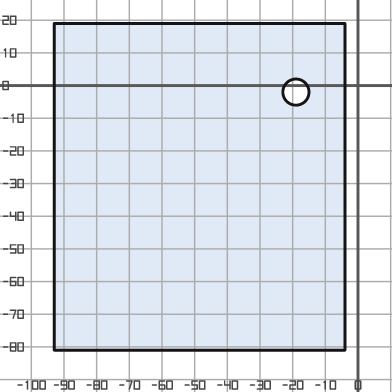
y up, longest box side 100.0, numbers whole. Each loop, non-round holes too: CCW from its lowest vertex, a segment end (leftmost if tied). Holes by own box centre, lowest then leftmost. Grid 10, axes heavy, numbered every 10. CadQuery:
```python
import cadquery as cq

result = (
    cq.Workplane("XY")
    .moveTo(-93.0, -81.0)
    .lineTo(-4.0, -81.0)
    .lineTo(-4.0, 19.0)
    .lineTo(-93.0, 19.0)
    .close()
    .moveTo(-19.0, -2.0)
    .circle(4.0)
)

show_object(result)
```